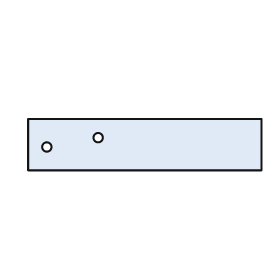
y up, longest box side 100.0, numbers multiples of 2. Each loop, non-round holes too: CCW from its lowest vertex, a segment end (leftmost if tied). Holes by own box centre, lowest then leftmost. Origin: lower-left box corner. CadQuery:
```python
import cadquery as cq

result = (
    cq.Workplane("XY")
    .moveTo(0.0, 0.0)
    .lineTo(100.0, 0.0)
    .lineTo(100.0, 22.0)
    .lineTo(0.0, 22.0)
    .close()
    .moveTo(8.0, 10.0)
    .circle(2.0)
    .moveTo(30.0, 14.0)
    .circle(2.0)
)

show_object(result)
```